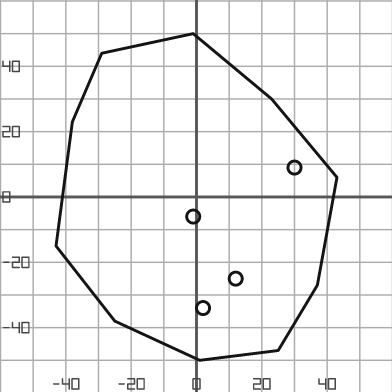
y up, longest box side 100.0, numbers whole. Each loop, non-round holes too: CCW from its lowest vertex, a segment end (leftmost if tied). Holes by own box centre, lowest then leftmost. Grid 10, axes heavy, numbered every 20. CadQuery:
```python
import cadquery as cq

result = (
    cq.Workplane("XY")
    .moveTo(1.0, -50.0)
    .lineTo(25.0, -47.0)
    .lineTo(37.0, -27.0)
    .lineTo(43.0, 6.0)
    .lineTo(23.0, 30.0)
    .lineTo(-1.0, 50.0)
    .lineTo(-29.0, 44.0)
    .lineTo(-38.0, 23.0)
    .lineTo(-43.0, -15.0)
    .lineTo(-25.0, -38.0)
    .close()
    .moveTo(2.0, -34.0)
    .circle(2.0)
    .moveTo(12.0, -25.0)
    .circle(2.0)
    .moveTo(-1.0, -6.0)
    .circle(2.0)
    .moveTo(30.0, 9.0)
    .circle(2.0)
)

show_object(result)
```